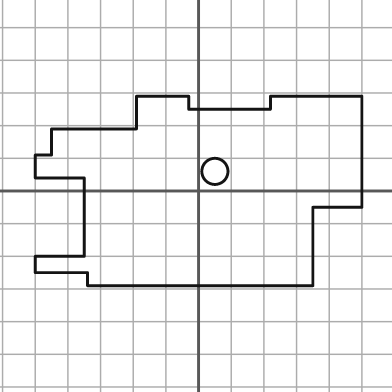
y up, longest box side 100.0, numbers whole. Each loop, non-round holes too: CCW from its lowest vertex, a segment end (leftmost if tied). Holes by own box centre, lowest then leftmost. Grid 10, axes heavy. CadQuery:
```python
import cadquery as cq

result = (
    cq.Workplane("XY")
    .moveTo(-34.0, -29.0)
    .lineTo(35.0, -29.0)
    .lineTo(35.0, -5.0)
    .lineTo(50.0, -5.0)
    .lineTo(50.0, 29.0)
    .lineTo(22.0, 29.0)
    .lineTo(22.0, 25.0)
    .lineTo(-3.0, 25.0)
    .lineTo(-3.0, 29.0)
    .lineTo(-19.0, 29.0)
    .lineTo(-19.0, 19.0)
    .lineTo(-45.0, 19.0)
    .lineTo(-45.0, 11.0)
    .lineTo(-50.0, 11.0)
    .lineTo(-50.0, 4.0)
    .lineTo(-35.0, 4.0)
    .lineTo(-35.0, -20.0)
    .lineTo(-50.0, -20.0)
    .lineTo(-50.0, -25.0)
    .lineTo(-34.0, -25.0)
    .close()
    .moveTo(5.0, 6.0)
    .circle(4.0)
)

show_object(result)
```